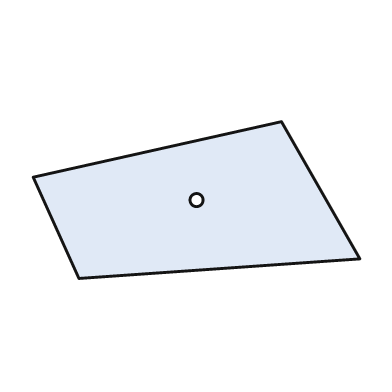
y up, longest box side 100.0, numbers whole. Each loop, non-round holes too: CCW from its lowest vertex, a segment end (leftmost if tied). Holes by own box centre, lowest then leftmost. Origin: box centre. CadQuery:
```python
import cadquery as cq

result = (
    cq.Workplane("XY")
    .moveTo(-36.0, -24.0)
    .lineTo(50.0, -18.0)
    .lineTo(26.0, 24.0)
    .lineTo(-50.0, 7.0)
    .close()
    .moveTo(0.0, 0.0)
    .circle(2.0)
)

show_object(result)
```